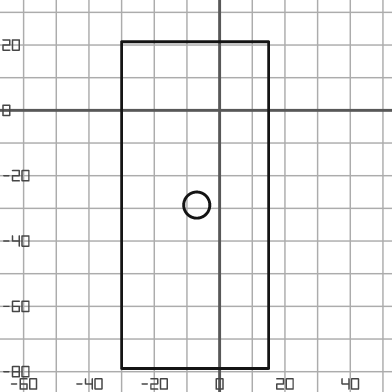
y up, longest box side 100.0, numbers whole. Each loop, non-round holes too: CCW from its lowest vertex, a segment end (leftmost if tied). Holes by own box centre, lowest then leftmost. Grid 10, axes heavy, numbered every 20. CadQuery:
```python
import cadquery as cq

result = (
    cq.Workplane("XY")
    .moveTo(-30.0, -79.0)
    .lineTo(15.0, -79.0)
    .lineTo(15.0, 21.0)
    .lineTo(-30.0, 21.0)
    .close()
    .moveTo(-7.0, -29.0)
    .circle(4.0)
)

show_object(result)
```